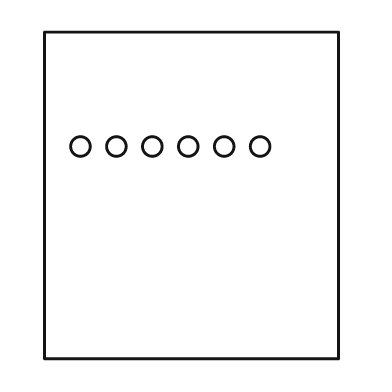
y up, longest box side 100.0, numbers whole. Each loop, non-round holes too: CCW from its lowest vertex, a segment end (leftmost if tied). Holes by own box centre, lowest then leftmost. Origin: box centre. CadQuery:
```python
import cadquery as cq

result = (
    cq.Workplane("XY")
    .moveTo(-45.0, -50.0)
    .lineTo(45.0, -50.0)
    .lineTo(45.0, 50.0)
    .lineTo(-45.0, 50.0)
    .close()
    .moveTo(-34.0, 15.0)
    .circle(3.0)
    .moveTo(-23.0, 15.0)
    .circle(3.0)
    .moveTo(-12.0, 15.0)
    .circle(3.0)
    .moveTo(-1.0, 15.0)
    .circle(3.0)
    .moveTo(10.0, 15.0)
    .circle(3.0)
    .moveTo(21.0, 15.0)
    .circle(3.0)
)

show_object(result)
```